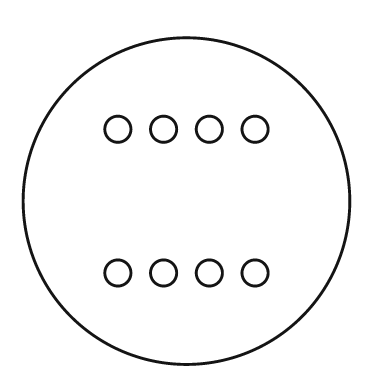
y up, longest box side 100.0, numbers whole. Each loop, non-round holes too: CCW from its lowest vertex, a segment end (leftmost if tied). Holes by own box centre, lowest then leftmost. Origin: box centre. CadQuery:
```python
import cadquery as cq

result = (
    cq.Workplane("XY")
    .moveTo(0.0, 0.0)
    .circle(50.0)
    .moveTo(-21.0, -22.0)
    .circle(4.0)
    .moveTo(-7.0, -22.0)
    .circle(4.0)
    .moveTo(7.0, -22.0)
    .circle(4.0)
    .moveTo(21.0, -22.0)
    .circle(4.0)
    .moveTo(-21.0, 22.0)
    .circle(4.0)
    .moveTo(-7.0, 22.0)
    .circle(4.0)
    .moveTo(7.0, 22.0)
    .circle(4.0)
    .moveTo(21.0, 22.0)
    .circle(4.0)
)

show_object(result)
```